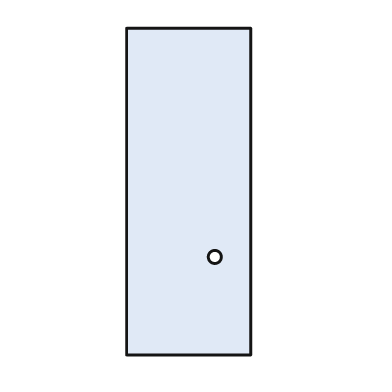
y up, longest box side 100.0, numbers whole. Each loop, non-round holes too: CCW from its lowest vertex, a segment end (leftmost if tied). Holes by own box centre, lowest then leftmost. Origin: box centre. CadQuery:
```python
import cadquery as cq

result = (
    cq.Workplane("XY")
    .moveTo(-19.0, -50.0)
    .lineTo(19.0, -50.0)
    .lineTo(19.0, 50.0)
    .lineTo(-19.0, 50.0)
    .close()
    .moveTo(8.0, -20.0)
    .circle(2.0)
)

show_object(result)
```